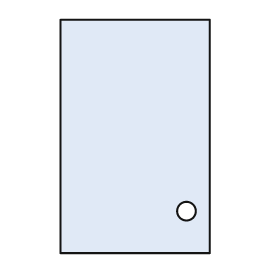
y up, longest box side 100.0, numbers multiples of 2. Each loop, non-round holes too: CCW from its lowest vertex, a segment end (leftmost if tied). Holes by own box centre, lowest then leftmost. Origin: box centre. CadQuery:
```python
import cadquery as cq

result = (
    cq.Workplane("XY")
    .moveTo(-32.0, -50.0)
    .lineTo(32.0, -50.0)
    .lineTo(32.0, 50.0)
    .lineTo(-32.0, 50.0)
    .close()
    .moveTo(22.0, -32.0)
    .circle(4.0)
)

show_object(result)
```